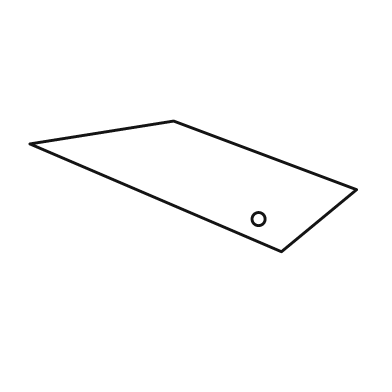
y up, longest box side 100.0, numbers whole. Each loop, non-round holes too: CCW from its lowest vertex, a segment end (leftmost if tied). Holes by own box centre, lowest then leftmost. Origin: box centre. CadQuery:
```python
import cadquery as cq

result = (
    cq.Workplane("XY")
    .moveTo(27.0, -20.0)
    .lineTo(50.0, -1.0)
    .lineTo(-6.0, 20.0)
    .lineTo(-50.0, 13.0)
    .close()
    .moveTo(20.0, -10.0)
    .circle(2.0)
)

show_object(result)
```